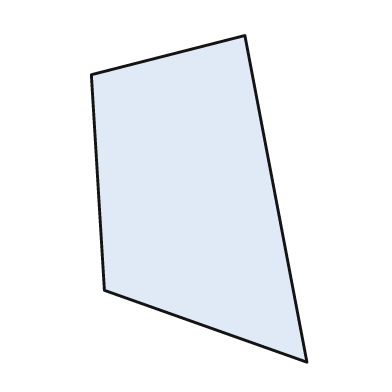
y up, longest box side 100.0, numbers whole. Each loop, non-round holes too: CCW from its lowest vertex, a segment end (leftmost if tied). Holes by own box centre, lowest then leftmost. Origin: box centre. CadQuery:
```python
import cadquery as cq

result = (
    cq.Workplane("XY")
    .moveTo(33.0, -50.0)
    .lineTo(14.0, 50.0)
    .lineTo(-33.0, 38.0)
    .lineTo(-29.0, -28.0)
    .close()
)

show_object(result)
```